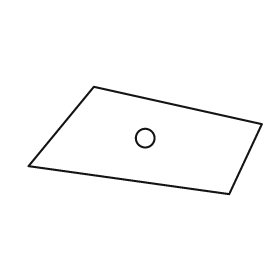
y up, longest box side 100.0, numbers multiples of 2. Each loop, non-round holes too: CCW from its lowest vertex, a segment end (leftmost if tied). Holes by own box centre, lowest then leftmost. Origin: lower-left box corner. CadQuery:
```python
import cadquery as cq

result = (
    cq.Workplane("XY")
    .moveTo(86.0, 0.0)
    .lineTo(100.0, 30.0)
    .lineTo(28.0, 46.0)
    .lineTo(0.0, 12.0)
    .close()
    .moveTo(50.0, 24.0)
    .circle(4.0)
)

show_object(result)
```